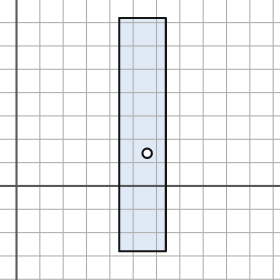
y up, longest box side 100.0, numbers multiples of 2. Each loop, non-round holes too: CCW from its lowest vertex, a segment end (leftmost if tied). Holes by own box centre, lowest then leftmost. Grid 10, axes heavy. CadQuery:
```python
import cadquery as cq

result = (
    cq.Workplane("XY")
    .moveTo(44.0, -28.0)
    .lineTo(64.0, -28.0)
    .lineTo(64.0, 72.0)
    .lineTo(44.0, 72.0)
    .close()
    .moveTo(56.0, 14.0)
    .circle(2.0)
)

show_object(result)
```